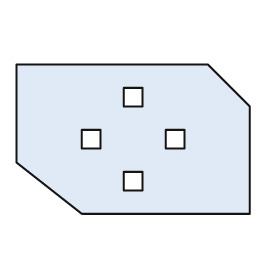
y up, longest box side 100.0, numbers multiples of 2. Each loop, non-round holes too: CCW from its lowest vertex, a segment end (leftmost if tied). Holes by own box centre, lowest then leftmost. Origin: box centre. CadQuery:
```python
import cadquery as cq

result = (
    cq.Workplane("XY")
    .moveTo(-22.0, -32.0)
    .lineTo(50.0, -32.0)
    .lineTo(50.0, 14.0)
    .lineTo(32.0, 32.0)
    .lineTo(-50.0, 32.0)
    .lineTo(-50.0, -10.0)
    .close()
    .moveTo(-4.0, -22.0)
    .lineTo(4.0, -22.0)
    .lineTo(4.0, -14.0)
    .lineTo(-4.0, -14.0)
    .close()
    .moveTo(-22.0, -4.0)
    .lineTo(-14.0, -4.0)
    .lineTo(-14.0, 4.0)
    .lineTo(-22.0, 4.0)
    .close()
    .moveTo(14.0, -4.0)
    .lineTo(22.0, -4.0)
    .lineTo(22.0, 4.0)
    .lineTo(14.0, 4.0)
    .close()
    .moveTo(-4.0, 14.0)
    .lineTo(4.0, 14.0)
    .lineTo(4.0, 22.0)
    .lineTo(-4.0, 22.0)
    .close()
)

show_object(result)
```